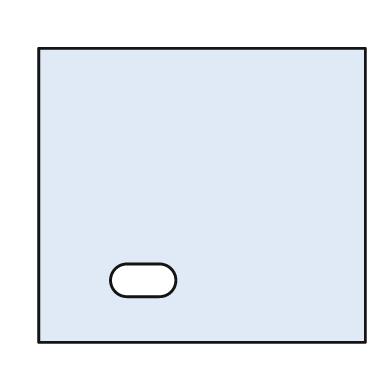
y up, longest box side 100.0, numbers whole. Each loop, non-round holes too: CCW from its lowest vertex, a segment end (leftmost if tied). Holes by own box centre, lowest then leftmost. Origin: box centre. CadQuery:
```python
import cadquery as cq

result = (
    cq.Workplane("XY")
    .moveTo(-50.0, -45.0)
    .lineTo(50.0, -45.0)
    .lineTo(50.0, 45.0)
    .lineTo(-50.0, 45.0)
    .close()
    .moveTo(-23.0, -31.0)
    .lineTo(-13.0, -31.0)
    .threePointArc((-8.0, -26.0), (-13.0, -21.0))
    .lineTo(-23.0, -21.0)
    .threePointArc((-28.0, -26.0), (-23.0, -31.0))
    .close()
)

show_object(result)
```